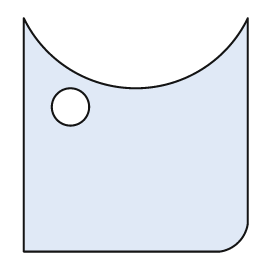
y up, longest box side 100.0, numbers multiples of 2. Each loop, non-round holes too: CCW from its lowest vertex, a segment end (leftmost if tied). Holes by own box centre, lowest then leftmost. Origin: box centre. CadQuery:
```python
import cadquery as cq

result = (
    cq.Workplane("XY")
    .moveTo(-48.0, -50.0)
    .lineTo(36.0, -50.0)
    .threePointArc((44.0, -46.0), (48.0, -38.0))
    .lineTo(48.0, 50.0)
    .threePointArc((0.0, 20.0), (-48.0, 50.0))
    .close()
    .moveTo(-28.0, 12.0)
    .circle(8.0)
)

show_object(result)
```